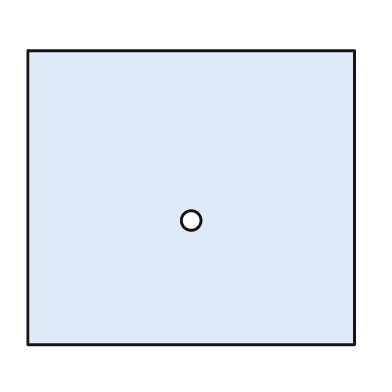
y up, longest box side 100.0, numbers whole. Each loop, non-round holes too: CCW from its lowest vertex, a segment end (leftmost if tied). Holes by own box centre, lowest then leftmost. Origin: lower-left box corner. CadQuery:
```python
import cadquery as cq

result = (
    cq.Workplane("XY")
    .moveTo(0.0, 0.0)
    .lineTo(100.0, 0.0)
    .lineTo(100.0, 90.0)
    .lineTo(0.0, 90.0)
    .close()
    .moveTo(50.0, 38.0)
    .circle(3.0)
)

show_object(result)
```